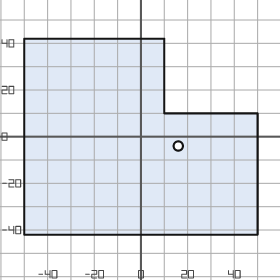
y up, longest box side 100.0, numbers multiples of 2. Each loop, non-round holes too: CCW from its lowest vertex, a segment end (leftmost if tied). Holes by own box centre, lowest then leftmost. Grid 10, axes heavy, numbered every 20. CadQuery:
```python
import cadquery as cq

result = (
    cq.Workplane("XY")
    .moveTo(-50.0, -42.0)
    .lineTo(50.0, -42.0)
    .lineTo(50.0, 10.0)
    .lineTo(10.0, 10.0)
    .lineTo(10.0, 42.0)
    .lineTo(-50.0, 42.0)
    .close()
    .moveTo(16.0, -4.0)
    .circle(2.0)
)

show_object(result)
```